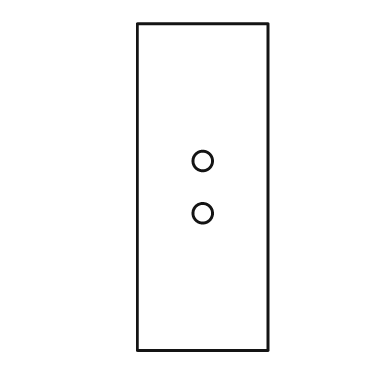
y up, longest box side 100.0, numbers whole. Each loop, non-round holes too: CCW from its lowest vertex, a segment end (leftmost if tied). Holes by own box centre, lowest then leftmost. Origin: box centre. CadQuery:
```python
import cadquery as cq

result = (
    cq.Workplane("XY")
    .moveTo(-20.0, -50.0)
    .lineTo(20.0, -50.0)
    .lineTo(20.0, 50.0)
    .lineTo(-20.0, 50.0)
    .close()
    .moveTo(0.0, -8.0)
    .circle(3.0)
    .moveTo(0.0, 8.0)
    .circle(3.0)
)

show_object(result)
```